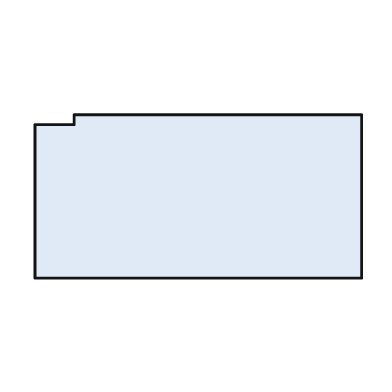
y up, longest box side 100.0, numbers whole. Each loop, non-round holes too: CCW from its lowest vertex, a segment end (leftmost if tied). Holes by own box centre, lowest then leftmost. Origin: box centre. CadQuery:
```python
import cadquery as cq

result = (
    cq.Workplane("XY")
    .moveTo(-50.0, -25.0)
    .lineTo(50.0, -25.0)
    .lineTo(50.0, 25.0)
    .lineTo(-38.0, 25.0)
    .lineTo(-38.0, 22.0)
    .lineTo(-50.0, 22.0)
    .close()
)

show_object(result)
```